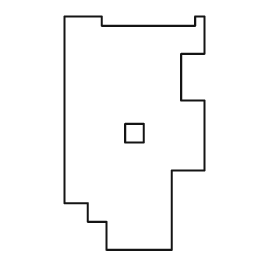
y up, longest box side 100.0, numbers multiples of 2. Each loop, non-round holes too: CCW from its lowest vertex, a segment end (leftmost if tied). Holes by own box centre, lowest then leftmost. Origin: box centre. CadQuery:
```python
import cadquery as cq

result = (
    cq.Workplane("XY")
    .moveTo(-12.0, -50.0)
    .lineTo(16.0, -50.0)
    .lineTo(16.0, -16.0)
    .lineTo(30.0, -16.0)
    .lineTo(30.0, 14.0)
    .lineTo(20.0, 14.0)
    .lineTo(20.0, 34.0)
    .lineTo(30.0, 34.0)
    .lineTo(30.0, 50.0)
    .lineTo(26.0, 50.0)
    .lineTo(26.0, 46.0)
    .lineTo(-14.0, 46.0)
    .lineTo(-14.0, 50.0)
    .lineTo(-30.0, 50.0)
    .lineTo(-30.0, -30.0)
    .lineTo(-20.0, -30.0)
    .lineTo(-20.0, -38.0)
    .lineTo(-12.0, -38.0)
    .close()
    .moveTo(-4.0, -4.0)
    .lineTo(4.0, -4.0)
    .lineTo(4.0, 4.0)
    .lineTo(-4.0, 4.0)
    .close()
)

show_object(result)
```